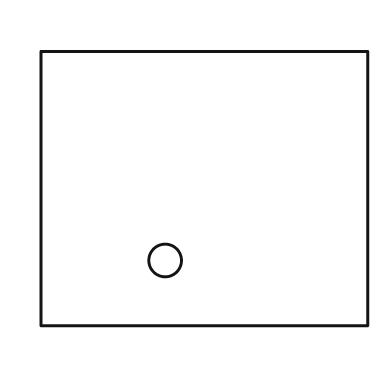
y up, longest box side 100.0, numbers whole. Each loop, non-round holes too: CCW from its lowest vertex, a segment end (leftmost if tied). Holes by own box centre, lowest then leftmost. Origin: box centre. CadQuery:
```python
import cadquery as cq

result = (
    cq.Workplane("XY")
    .moveTo(-50.0, -42.0)
    .lineTo(50.0, -42.0)
    .lineTo(50.0, 42.0)
    .lineTo(-50.0, 42.0)
    .close()
    .moveTo(-12.0, -22.0)
    .circle(5.0)
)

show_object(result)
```